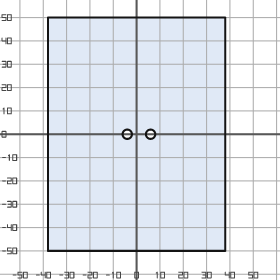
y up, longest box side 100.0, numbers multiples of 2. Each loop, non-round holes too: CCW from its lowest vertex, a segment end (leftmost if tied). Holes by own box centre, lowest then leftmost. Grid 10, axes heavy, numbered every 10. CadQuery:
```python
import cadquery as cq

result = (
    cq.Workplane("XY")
    .moveTo(-38.0, -50.0)
    .lineTo(38.0, -50.0)
    .lineTo(38.0, 50.0)
    .lineTo(-38.0, 50.0)
    .close()
    .moveTo(-4.0, 0.0)
    .circle(2.0)
    .moveTo(6.0, 0.0)
    .circle(2.0)
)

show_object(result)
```